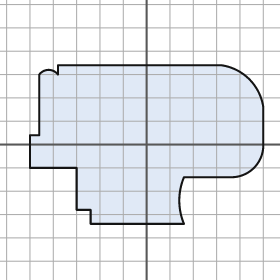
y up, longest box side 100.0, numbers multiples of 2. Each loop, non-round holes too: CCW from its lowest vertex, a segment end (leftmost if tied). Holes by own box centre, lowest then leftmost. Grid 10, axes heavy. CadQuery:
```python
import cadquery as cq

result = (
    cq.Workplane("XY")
    .moveTo(-24.0, -34.0)
    .lineTo(16.0, -34.0)
    .threePointArc((14.0, -24.0), (16.0, -14.0))
    .lineTo(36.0, -14.0)
    .threePointArc((46.0, -10.0), (50.0, 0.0))
    .lineTo(50.0, 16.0)
    .threePointArc((44.0, 28.0), (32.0, 34.0))
    .lineTo(-38.0, 34.0)
    .lineTo(-38.0, 30.0)
    .threePointArc((-42.0, 32.0), (-46.0, 30.0))
    .lineTo(-46.0, 4.0)
    .lineTo(-50.0, 4.0)
    .lineTo(-50.0, -10.0)
    .lineTo(-30.0, -10.0)
    .lineTo(-30.0, -28.0)
    .lineTo(-24.0, -28.0)
    .close()
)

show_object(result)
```